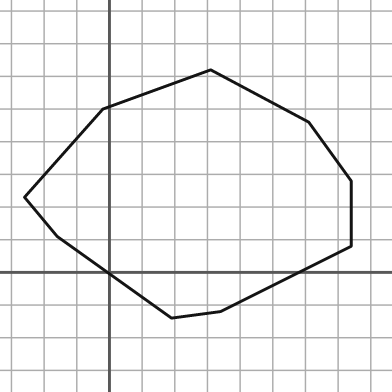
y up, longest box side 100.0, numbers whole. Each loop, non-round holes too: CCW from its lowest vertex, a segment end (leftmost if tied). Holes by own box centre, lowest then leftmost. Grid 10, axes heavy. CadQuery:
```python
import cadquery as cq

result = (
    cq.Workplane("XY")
    .moveTo(19.0, -14.0)
    .lineTo(34.0, -12.0)
    .lineTo(74.0, 8.0)
    .lineTo(74.0, 28.0)
    .lineTo(61.0, 46.0)
    .lineTo(31.0, 62.0)
    .lineTo(-2.0, 50.0)
    .lineTo(-26.0, 23.0)
    .lineTo(-16.0, 11.0)
    .close()
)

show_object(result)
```